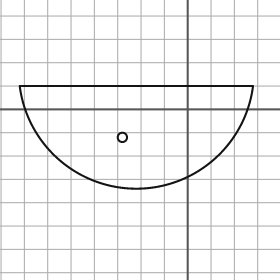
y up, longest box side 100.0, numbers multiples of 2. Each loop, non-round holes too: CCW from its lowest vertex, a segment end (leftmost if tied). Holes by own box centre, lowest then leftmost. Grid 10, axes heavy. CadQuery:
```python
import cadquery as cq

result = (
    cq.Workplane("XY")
    .moveTo(-72.0, 10.0)
    .threePointArc((-22.0, -34.0), (28.0, 10.0))
    .close()
    .moveTo(-28.0, -12.0)
    .circle(2.0)
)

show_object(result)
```